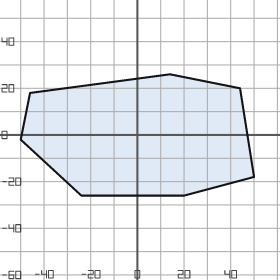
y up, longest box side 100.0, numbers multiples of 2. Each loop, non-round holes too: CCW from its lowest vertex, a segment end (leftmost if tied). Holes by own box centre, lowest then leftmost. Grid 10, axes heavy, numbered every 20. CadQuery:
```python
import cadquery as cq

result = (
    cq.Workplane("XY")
    .moveTo(-24.0, -26.0)
    .lineTo(20.0, -26.0)
    .lineTo(50.0, -18.0)
    .lineTo(44.0, 20.0)
    .lineTo(14.0, 26.0)
    .lineTo(-46.0, 18.0)
    .lineTo(-50.0, -2.0)
    .close()
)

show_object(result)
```